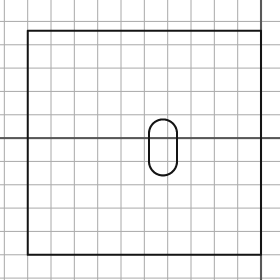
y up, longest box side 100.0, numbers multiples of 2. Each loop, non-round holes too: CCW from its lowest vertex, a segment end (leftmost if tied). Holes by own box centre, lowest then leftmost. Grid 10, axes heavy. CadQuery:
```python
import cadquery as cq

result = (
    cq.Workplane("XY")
    .moveTo(-100.0, -50.0)
    .lineTo(0.0, -50.0)
    .lineTo(0.0, 46.0)
    .lineTo(-100.0, 46.0)
    .close()
    .moveTo(-48.0, -10.0)
    .threePointArc((-42.0, -16.0), (-36.0, -10.0))
    .lineTo(-36.0, 2.0)
    .threePointArc((-42.0, 8.0), (-48.0, 2.0))
    .close()
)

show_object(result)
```